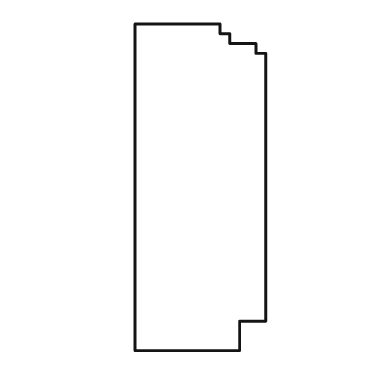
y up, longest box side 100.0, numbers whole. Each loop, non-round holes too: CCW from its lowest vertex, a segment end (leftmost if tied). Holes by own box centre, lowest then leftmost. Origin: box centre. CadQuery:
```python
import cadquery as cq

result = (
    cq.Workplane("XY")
    .moveTo(-20.0, -50.0)
    .lineTo(12.0, -50.0)
    .lineTo(12.0, -41.0)
    .lineTo(20.0, -41.0)
    .lineTo(20.0, 41.0)
    .lineTo(17.0, 41.0)
    .lineTo(17.0, 44.0)
    .lineTo(9.0, 44.0)
    .lineTo(9.0, 47.0)
    .lineTo(6.0, 47.0)
    .lineTo(6.0, 50.0)
    .lineTo(-20.0, 50.0)
    .close()
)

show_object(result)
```